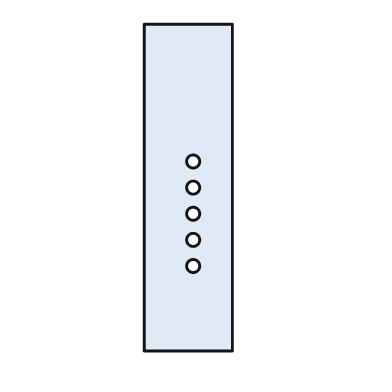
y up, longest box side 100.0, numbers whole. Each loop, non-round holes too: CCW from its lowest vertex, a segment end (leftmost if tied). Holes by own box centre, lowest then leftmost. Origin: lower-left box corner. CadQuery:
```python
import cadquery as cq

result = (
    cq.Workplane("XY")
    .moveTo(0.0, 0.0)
    .lineTo(27.0, 0.0)
    .lineTo(27.0, 100.0)
    .lineTo(0.0, 100.0)
    .close()
    .moveTo(15.0, 26.0)
    .circle(2.0)
    .moveTo(15.0, 34.0)
    .circle(2.0)
    .moveTo(15.0, 42.0)
    .circle(2.0)
    .moveTo(15.0, 50.0)
    .circle(2.0)
    .moveTo(15.0, 58.0)
    .circle(2.0)
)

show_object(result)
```